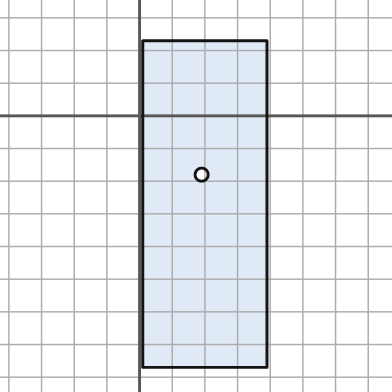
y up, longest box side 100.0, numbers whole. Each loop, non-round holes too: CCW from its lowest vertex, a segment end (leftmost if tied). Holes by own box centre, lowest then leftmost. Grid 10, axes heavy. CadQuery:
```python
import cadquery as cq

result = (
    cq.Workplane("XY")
    .moveTo(1.0, -77.0)
    .lineTo(39.0, -77.0)
    .lineTo(39.0, 23.0)
    .lineTo(1.0, 23.0)
    .close()
    .moveTo(19.0, -18.0)
    .circle(2.0)
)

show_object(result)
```